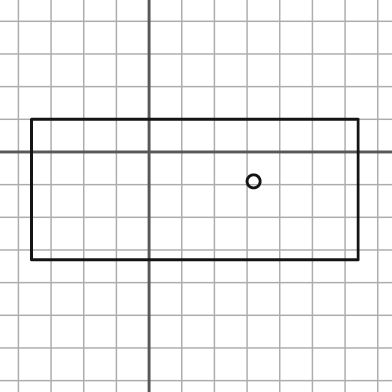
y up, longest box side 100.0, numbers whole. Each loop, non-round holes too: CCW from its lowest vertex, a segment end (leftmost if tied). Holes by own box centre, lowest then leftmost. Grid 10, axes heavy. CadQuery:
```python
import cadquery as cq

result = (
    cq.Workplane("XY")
    .moveTo(-36.0, -33.0)
    .lineTo(64.0, -33.0)
    .lineTo(64.0, 10.0)
    .lineTo(-36.0, 10.0)
    .close()
    .moveTo(32.0, -9.0)
    .circle(2.0)
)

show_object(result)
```